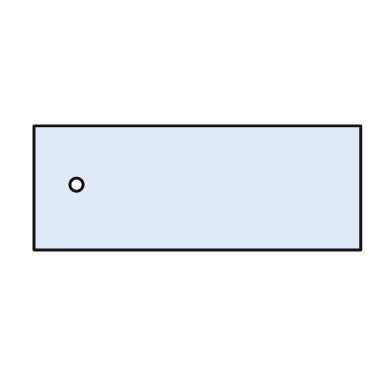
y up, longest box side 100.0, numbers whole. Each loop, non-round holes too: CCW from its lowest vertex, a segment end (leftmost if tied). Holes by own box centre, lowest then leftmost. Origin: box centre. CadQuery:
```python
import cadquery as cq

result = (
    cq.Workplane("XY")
    .moveTo(-50.0, -19.0)
    .lineTo(50.0, -19.0)
    .lineTo(50.0, 19.0)
    .lineTo(-50.0, 19.0)
    .close()
    .moveTo(-37.0, 1.0)
    .circle(2.0)
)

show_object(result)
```